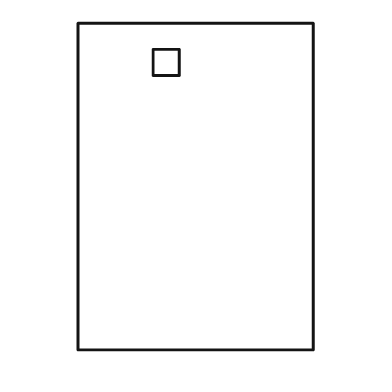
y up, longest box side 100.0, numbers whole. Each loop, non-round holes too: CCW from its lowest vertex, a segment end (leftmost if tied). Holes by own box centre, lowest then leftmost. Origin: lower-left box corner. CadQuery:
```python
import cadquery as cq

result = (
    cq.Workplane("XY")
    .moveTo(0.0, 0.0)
    .lineTo(72.0, 0.0)
    .lineTo(72.0, 100.0)
    .lineTo(0.0, 100.0)
    .close()
    .moveTo(23.0, 84.0)
    .lineTo(31.0, 84.0)
    .lineTo(31.0, 92.0)
    .lineTo(23.0, 92.0)
    .close()
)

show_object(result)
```